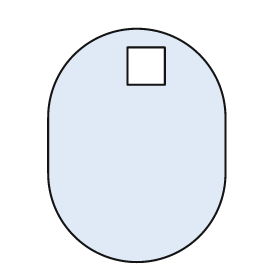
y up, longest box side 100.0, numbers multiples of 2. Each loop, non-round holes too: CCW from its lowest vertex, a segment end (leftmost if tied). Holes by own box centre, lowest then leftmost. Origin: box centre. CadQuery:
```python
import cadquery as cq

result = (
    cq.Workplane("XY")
    .moveTo(-38.0, -12.0)
    .threePointArc((0.0, -50.0), (38.0, -12.0))
    .lineTo(38.0, 12.0)
    .threePointArc((0.0, 50.0), (-38.0, 12.0))
    .close()
    .moveTo(-4.0, 26.0)
    .lineTo(12.0, 26.0)
    .lineTo(12.0, 42.0)
    .lineTo(-4.0, 42.0)
    .close()
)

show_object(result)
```